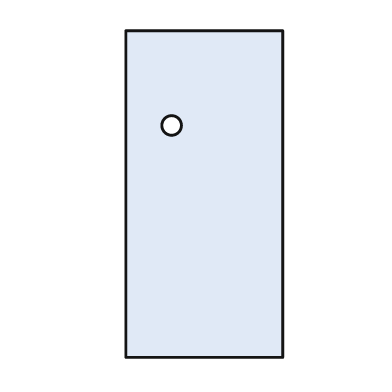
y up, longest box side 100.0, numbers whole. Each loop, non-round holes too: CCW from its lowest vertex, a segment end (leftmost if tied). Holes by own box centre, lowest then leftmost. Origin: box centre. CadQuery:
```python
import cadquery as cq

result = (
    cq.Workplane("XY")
    .moveTo(-24.0, -50.0)
    .lineTo(24.0, -50.0)
    .lineTo(24.0, 50.0)
    .lineTo(-24.0, 50.0)
    .close()
    .moveTo(-10.0, 21.0)
    .circle(3.0)
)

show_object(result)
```